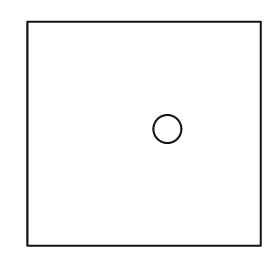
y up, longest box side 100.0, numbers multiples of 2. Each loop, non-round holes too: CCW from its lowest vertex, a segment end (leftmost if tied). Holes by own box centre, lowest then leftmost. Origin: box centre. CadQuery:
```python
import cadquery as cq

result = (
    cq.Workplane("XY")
    .moveTo(-50.0, -48.0)
    .lineTo(50.0, -48.0)
    .lineTo(50.0, 48.0)
    .lineTo(-50.0, 48.0)
    .close()
    .moveTo(10.0, 2.0)
    .circle(6.0)
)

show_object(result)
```